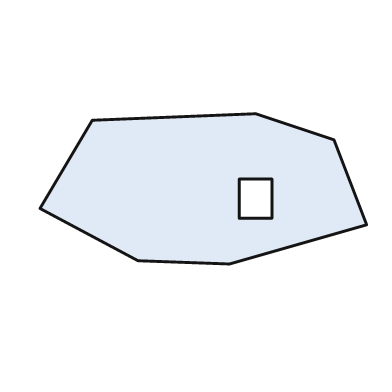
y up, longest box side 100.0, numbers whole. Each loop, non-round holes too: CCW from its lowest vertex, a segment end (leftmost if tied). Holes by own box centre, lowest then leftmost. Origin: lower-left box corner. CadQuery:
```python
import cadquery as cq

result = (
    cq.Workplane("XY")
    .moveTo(58.0, 0.0)
    .lineTo(100.0, 12.0)
    .lineTo(90.0, 38.0)
    .lineTo(66.0, 46.0)
    .lineTo(16.0, 44.0)
    .lineTo(0.0, 17.0)
    .lineTo(30.0, 1.0)
    .close()
    .moveTo(61.0, 14.0)
    .lineTo(71.0, 14.0)
    .lineTo(71.0, 26.0)
    .lineTo(61.0, 26.0)
    .close()
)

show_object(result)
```